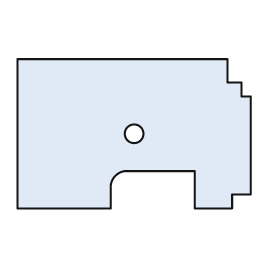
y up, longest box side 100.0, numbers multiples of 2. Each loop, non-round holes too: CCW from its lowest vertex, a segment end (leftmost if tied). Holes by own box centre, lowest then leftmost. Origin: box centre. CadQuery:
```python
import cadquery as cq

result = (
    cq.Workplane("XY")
    .moveTo(-50.0, -32.0)
    .lineTo(-10.0, -32.0)
    .lineTo(-10.0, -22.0)
    .threePointArc((-8.0, -18.0), (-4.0, -16.0))
    .lineTo(26.0, -16.0)
    .lineTo(26.0, -32.0)
    .lineTo(42.0, -32.0)
    .lineTo(42.0, -26.0)
    .lineTo(50.0, -26.0)
    .lineTo(50.0, 16.0)
    .lineTo(46.0, 16.0)
    .lineTo(46.0, 22.0)
    .lineTo(40.0, 22.0)
    .lineTo(40.0, 32.0)
    .lineTo(-50.0, 32.0)
    .close()
    .moveTo(0.0, 0.0)
    .circle(4.0)
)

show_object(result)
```